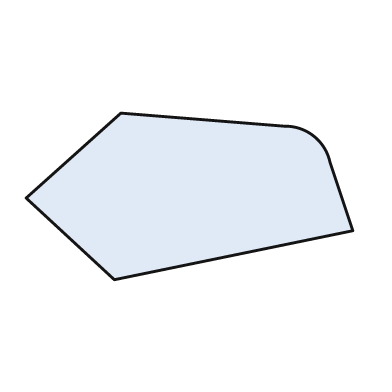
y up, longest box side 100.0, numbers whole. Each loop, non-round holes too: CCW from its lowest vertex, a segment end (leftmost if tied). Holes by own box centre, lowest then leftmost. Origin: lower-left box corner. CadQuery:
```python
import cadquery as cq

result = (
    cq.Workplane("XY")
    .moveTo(27.0, 0.0)
    .lineTo(100.0, 15.0)
    .lineTo(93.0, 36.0)
    .threePointArc((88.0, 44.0), (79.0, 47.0))
    .lineTo(29.0, 51.0)
    .lineTo(0.0, 25.0)
    .close()
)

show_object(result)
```